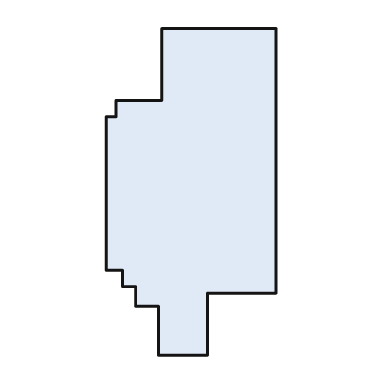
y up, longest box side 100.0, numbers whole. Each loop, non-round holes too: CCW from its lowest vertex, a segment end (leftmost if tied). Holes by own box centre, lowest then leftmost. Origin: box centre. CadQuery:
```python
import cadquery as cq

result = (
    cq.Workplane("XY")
    .moveTo(-10.0, -50.0)
    .lineTo(5.0, -50.0)
    .lineTo(5.0, -31.0)
    .lineTo(26.0, -31.0)
    .lineTo(26.0, 50.0)
    .lineTo(-9.0, 50.0)
    .lineTo(-9.0, 28.0)
    .lineTo(-23.0, 28.0)
    .lineTo(-23.0, 23.0)
    .lineTo(-26.0, 23.0)
    .lineTo(-26.0, -24.0)
    .lineTo(-21.0, -24.0)
    .lineTo(-21.0, -29.0)
    .lineTo(-17.0, -29.0)
    .lineTo(-17.0, -35.0)
    .lineTo(-10.0, -35.0)
    .close()
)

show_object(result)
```